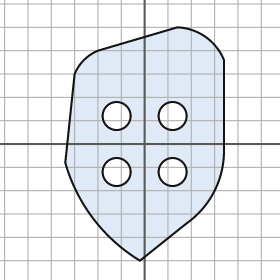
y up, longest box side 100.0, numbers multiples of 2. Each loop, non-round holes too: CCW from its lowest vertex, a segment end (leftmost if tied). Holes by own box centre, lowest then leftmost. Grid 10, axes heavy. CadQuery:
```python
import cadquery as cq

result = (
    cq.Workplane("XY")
    .moveTo(-2.0, -50.0)
    .lineTo(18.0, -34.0)
    .threePointArc((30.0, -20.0), (34.0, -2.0))
    .lineTo(34.0, 36.0)
    .threePointArc((26.0, 46.0), (14.0, 50.0))
    .lineTo(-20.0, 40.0)
    .threePointArc((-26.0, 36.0), (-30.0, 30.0))
    .lineTo(-34.0, -8.0)
    .threePointArc((-22.0, -32.0), (-2.0, -50.0))
    .close()
    .moveTo(-12.0, -12.0)
    .circle(6.0)
    .moveTo(12.0, -12.0)
    .circle(6.0)
    .moveTo(-12.0, 12.0)
    .circle(6.0)
    .moveTo(12.0, 12.0)
    .circle(6.0)
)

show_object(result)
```